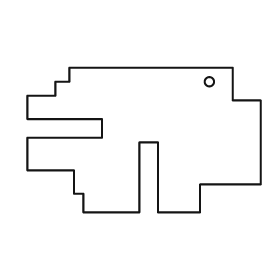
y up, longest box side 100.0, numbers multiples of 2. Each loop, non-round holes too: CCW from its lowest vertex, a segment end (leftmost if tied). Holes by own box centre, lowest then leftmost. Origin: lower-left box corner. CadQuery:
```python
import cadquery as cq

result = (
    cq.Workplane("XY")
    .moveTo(24.0, 0.0)
    .lineTo(48.0, 0.0)
    .lineTo(48.0, 30.0)
    .lineTo(56.0, 30.0)
    .lineTo(56.0, 0.0)
    .lineTo(74.0, 0.0)
    .lineTo(74.0, 12.0)
    .lineTo(100.0, 12.0)
    .lineTo(100.0, 48.0)
    .lineTo(88.0, 48.0)
    .lineTo(88.0, 62.0)
    .lineTo(18.0, 62.0)
    .lineTo(18.0, 56.0)
    .lineTo(12.0, 56.0)
    .lineTo(12.0, 50.0)
    .lineTo(0.0, 50.0)
    .lineTo(0.0, 40.0)
    .lineTo(32.0, 40.0)
    .lineTo(32.0, 32.0)
    .lineTo(0.0, 32.0)
    .lineTo(0.0, 18.0)
    .lineTo(20.0, 18.0)
    .lineTo(20.0, 8.0)
    .lineTo(24.0, 8.0)
    .close()
    .moveTo(78.0, 56.0)
    .circle(2.0)
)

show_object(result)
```